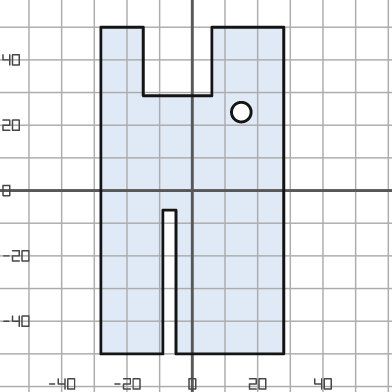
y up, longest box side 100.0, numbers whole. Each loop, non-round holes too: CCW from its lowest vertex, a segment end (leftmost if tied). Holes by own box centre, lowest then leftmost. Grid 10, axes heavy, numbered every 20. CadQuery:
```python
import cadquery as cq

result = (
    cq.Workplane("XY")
    .moveTo(-28.0, -50.0)
    .lineTo(-9.0, -50.0)
    .lineTo(-9.0, -6.0)
    .lineTo(-5.0, -6.0)
    .lineTo(-5.0, -50.0)
    .lineTo(28.0, -50.0)
    .lineTo(28.0, 50.0)
    .lineTo(6.0, 50.0)
    .lineTo(6.0, 29.0)
    .lineTo(-15.0, 29.0)
    .lineTo(-15.0, 50.0)
    .lineTo(-28.0, 50.0)
    .close()
    .moveTo(15.0, 24.0)
    .circle(3.0)
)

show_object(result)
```